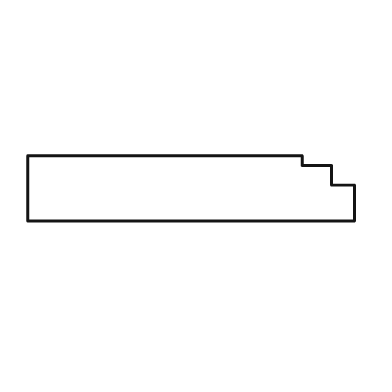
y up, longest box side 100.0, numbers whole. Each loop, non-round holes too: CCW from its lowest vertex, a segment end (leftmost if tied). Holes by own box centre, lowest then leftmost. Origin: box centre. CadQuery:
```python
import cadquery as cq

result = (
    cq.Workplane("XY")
    .moveTo(-50.0, -10.0)
    .lineTo(50.0, -10.0)
    .lineTo(50.0, 1.0)
    .lineTo(43.0, 1.0)
    .lineTo(43.0, 7.0)
    .lineTo(34.0, 7.0)
    .lineTo(34.0, 10.0)
    .lineTo(-50.0, 10.0)
    .close()
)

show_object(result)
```